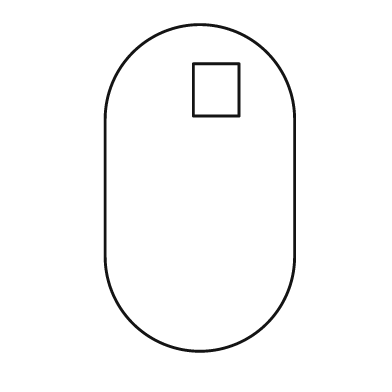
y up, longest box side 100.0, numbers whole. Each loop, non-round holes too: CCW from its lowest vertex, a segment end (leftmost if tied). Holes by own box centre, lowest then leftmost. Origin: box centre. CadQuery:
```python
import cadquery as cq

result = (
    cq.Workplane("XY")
    .moveTo(-29.0, -21.0)
    .threePointArc((0.0, -50.0), (29.0, -21.0))
    .lineTo(29.0, 21.0)
    .threePointArc((0.0, 50.0), (-29.0, 21.0))
    .close()
    .moveTo(-2.0, 22.0)
    .lineTo(12.0, 22.0)
    .lineTo(12.0, 38.0)
    .lineTo(-2.0, 38.0)
    .close()
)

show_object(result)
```